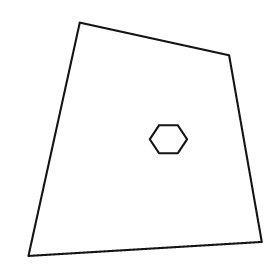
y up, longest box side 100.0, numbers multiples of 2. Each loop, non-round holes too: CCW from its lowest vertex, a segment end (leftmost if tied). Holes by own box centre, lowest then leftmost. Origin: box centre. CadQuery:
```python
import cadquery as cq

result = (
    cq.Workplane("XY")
    .moveTo(-50.0, -50.0)
    .lineTo(50.0, -44.0)
    .lineTo(36.0, 36.0)
    .lineTo(-28.0, 50.0)
    .close()
    .moveTo(6.0, -6.0)
    .lineTo(14.0, -6.0)
    .lineTo(18.0, 0.0)
    .lineTo(14.0, 6.0)
    .lineTo(6.0, 6.0)
    .lineTo(2.0, 0.0)
    .close()
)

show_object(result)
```